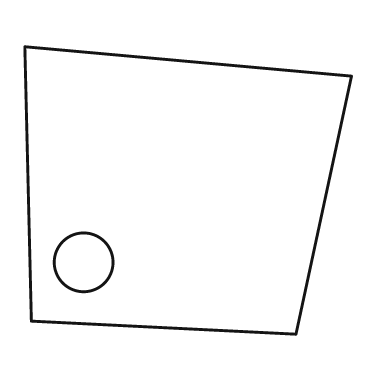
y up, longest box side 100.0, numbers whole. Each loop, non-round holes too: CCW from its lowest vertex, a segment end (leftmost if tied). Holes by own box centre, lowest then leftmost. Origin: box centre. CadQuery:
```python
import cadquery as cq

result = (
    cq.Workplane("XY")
    .moveTo(33.0, -44.0)
    .lineTo(50.0, 35.0)
    .lineTo(-50.0, 44.0)
    .lineTo(-48.0, -40.0)
    .close()
    .moveTo(-32.0, -22.0)
    .circle(9.0)
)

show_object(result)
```